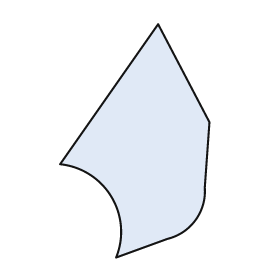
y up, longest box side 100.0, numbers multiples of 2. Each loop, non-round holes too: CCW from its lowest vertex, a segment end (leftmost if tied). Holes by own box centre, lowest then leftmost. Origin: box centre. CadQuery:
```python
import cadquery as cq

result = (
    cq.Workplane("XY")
    .moveTo(-8.0, -50.0)
    .lineTo(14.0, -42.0)
    .threePointArc((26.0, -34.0), (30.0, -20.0))
    .lineTo(32.0, 8.0)
    .lineTo(10.0, 50.0)
    .lineTo(-32.0, -10.0)
    .threePointArc((-10.0, -24.0), (-8.0, -50.0))
    .close()
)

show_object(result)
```